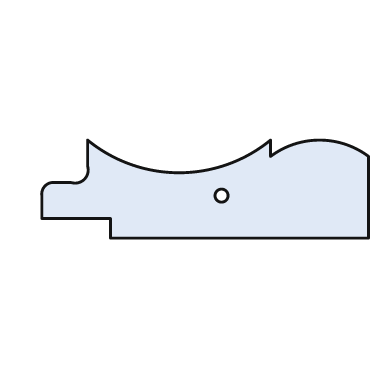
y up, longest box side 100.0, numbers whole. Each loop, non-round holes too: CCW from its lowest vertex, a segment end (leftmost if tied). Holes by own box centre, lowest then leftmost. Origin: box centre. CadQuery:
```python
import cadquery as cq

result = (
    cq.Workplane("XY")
    .moveTo(-29.0, -15.0)
    .lineTo(50.0, -15.0)
    .lineTo(50.0, 10.0)
    .threePointArc((35.0, 15.0), (20.0, 10.0))
    .lineTo(20.0, 15.0)
    .threePointArc((-8.0, 5.0), (-36.0, 15.0))
    .lineTo(-36.0, 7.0)
    .threePointArc((-37.0, 3.0), (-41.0, 2.0))
    .lineTo(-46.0, 2.0)
    .threePointArc((-49.0, 1.0), (-50.0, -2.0))
    .lineTo(-50.0, -9.0)
    .lineTo(-29.0, -9.0)
    .close()
    .moveTo(5.0, -2.0)
    .circle(2.0)
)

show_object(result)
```